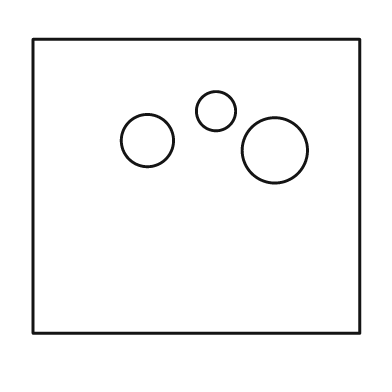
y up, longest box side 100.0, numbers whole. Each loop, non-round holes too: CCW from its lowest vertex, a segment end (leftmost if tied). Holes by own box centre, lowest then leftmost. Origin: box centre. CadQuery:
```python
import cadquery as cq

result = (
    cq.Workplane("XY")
    .moveTo(-50.0, -45.0)
    .lineTo(50.0, -45.0)
    .lineTo(50.0, 45.0)
    .lineTo(-50.0, 45.0)
    .close()
    .moveTo(24.0, 11.0)
    .circle(10.0)
    .moveTo(-15.0, 14.0)
    .circle(8.0)
    .moveTo(6.0, 23.0)
    .circle(6.0)
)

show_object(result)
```